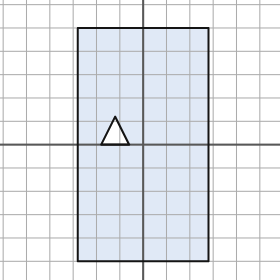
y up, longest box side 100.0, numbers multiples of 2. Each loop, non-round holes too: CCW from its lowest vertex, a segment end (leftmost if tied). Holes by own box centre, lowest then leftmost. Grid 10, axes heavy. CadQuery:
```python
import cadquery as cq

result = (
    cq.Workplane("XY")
    .moveTo(-28.0, -50.0)
    .lineTo(28.0, -50.0)
    .lineTo(28.0, 50.0)
    .lineTo(-28.0, 50.0)
    .close()
    .moveTo(-18.0, 0.0)
    .lineTo(-6.0, 0.0)
    .lineTo(-12.0, 12.0)
    .close()
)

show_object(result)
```